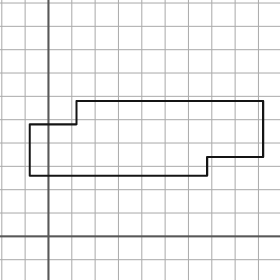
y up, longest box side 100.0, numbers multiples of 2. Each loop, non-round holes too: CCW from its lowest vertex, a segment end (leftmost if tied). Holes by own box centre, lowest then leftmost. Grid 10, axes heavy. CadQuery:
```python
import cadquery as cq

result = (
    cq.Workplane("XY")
    .moveTo(-8.0, 26.0)
    .lineTo(68.0, 26.0)
    .lineTo(68.0, 34.0)
    .lineTo(92.0, 34.0)
    .lineTo(92.0, 58.0)
    .lineTo(12.0, 58.0)
    .lineTo(12.0, 48.0)
    .lineTo(-8.0, 48.0)
    .close()
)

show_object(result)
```